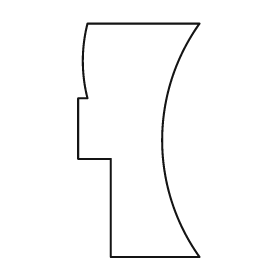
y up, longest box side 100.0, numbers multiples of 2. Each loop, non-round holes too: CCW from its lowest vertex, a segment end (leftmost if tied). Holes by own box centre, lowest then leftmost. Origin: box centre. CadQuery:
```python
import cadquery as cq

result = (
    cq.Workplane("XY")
    .moveTo(-12.0, -50.0)
    .lineTo(26.0, -50.0)
    .threePointArc((10.0, 0.0), (26.0, 50.0))
    .lineTo(-22.0, 50.0)
    .threePointArc((-24.0, 34.0), (-22.0, 18.0))
    .lineTo(-26.0, 18.0)
    .lineTo(-26.0, -8.0)
    .lineTo(-12.0, -8.0)
    .close()
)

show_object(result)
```